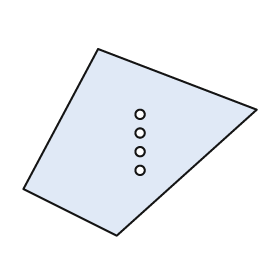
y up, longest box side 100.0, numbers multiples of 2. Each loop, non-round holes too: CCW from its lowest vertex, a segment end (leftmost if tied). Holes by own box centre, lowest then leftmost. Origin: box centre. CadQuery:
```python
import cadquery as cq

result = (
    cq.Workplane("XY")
    .moveTo(-10.0, -40.0)
    .lineTo(50.0, 14.0)
    .lineTo(-18.0, 40.0)
    .lineTo(-50.0, -20.0)
    .close()
    .moveTo(0.0, -12.0)
    .circle(2.0)
    .moveTo(0.0, -4.0)
    .circle(2.0)
    .moveTo(0.0, 4.0)
    .circle(2.0)
    .moveTo(0.0, 12.0)
    .circle(2.0)
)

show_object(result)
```